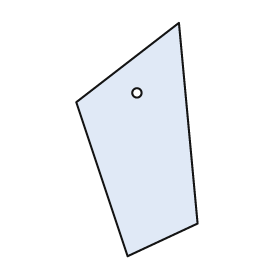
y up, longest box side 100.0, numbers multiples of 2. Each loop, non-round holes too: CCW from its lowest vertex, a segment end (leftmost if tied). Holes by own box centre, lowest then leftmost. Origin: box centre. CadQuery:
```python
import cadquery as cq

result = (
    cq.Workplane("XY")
    .moveTo(-4.0, -50.0)
    .lineTo(26.0, -36.0)
    .lineTo(18.0, 50.0)
    .lineTo(-26.0, 16.0)
    .close()
    .moveTo(0.0, 20.0)
    .circle(2.0)
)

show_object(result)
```